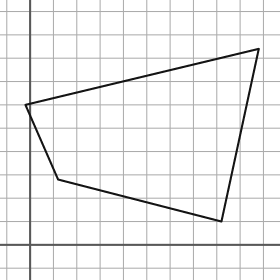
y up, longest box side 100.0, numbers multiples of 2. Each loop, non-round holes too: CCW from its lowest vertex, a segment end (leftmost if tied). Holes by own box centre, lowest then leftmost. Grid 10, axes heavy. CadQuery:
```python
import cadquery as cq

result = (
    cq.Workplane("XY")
    .moveTo(82.0, 10.0)
    .lineTo(98.0, 84.0)
    .lineTo(-2.0, 60.0)
    .lineTo(12.0, 28.0)
    .close()
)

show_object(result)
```